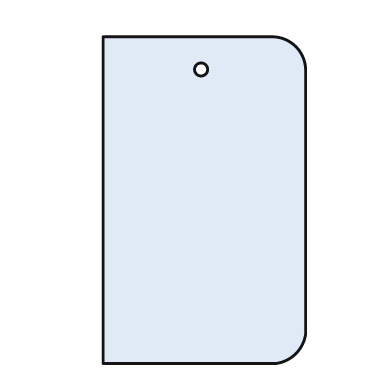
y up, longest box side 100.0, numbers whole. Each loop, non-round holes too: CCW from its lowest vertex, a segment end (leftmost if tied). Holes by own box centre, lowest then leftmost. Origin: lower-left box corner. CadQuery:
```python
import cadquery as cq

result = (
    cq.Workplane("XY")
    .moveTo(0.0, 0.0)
    .lineTo(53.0, 0.0)
    .threePointArc((59.0, 3.0), (62.0, 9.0))
    .lineTo(62.0, 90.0)
    .threePointArc((59.0, 97.0), (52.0, 100.0))
    .lineTo(0.0, 100.0)
    .close()
    .moveTo(30.0, 90.0)
    .circle(2.0)
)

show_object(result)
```